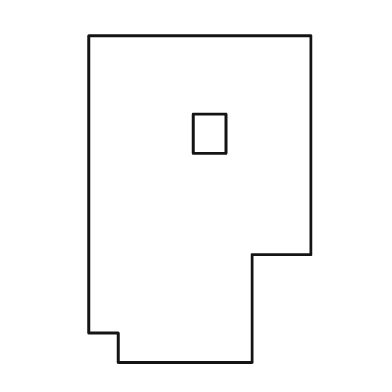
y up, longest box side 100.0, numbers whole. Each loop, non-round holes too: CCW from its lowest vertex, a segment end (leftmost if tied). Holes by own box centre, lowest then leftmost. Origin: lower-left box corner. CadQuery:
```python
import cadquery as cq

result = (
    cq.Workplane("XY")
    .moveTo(9.0, 0.0)
    .lineTo(50.0, 0.0)
    .lineTo(50.0, 33.0)
    .lineTo(68.0, 33.0)
    .lineTo(68.0, 100.0)
    .lineTo(0.0, 100.0)
    .lineTo(0.0, 9.0)
    .lineTo(9.0, 9.0)
    .close()
    .moveTo(32.0, 64.0)
    .lineTo(42.0, 64.0)
    .lineTo(42.0, 76.0)
    .lineTo(32.0, 76.0)
    .close()
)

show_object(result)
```